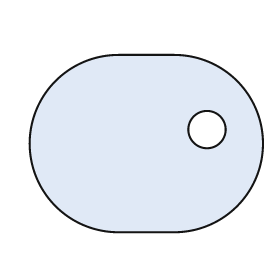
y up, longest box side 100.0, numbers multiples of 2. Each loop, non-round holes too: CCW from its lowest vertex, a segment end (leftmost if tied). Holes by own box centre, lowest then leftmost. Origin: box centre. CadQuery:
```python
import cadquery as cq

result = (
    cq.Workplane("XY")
    .moveTo(-12.0, -38.0)
    .lineTo(12.0, -38.0)
    .threePointArc((50.0, 0.0), (12.0, 38.0))
    .lineTo(-12.0, 38.0)
    .threePointArc((-50.0, 0.0), (-12.0, -38.0))
    .close()
    .moveTo(26.0, 6.0)
    .circle(8.0)
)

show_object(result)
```